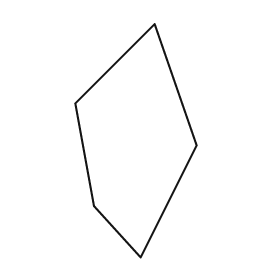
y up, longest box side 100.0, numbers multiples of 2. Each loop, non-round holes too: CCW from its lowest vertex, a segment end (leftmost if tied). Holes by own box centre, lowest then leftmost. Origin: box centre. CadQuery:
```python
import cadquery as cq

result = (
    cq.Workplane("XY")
    .moveTo(2.0, -50.0)
    .lineTo(26.0, -2.0)
    .lineTo(8.0, 50.0)
    .lineTo(-26.0, 16.0)
    .lineTo(-18.0, -28.0)
    .close()
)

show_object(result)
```